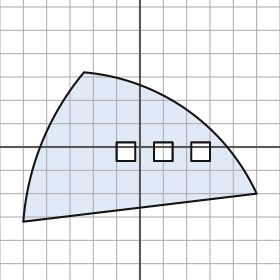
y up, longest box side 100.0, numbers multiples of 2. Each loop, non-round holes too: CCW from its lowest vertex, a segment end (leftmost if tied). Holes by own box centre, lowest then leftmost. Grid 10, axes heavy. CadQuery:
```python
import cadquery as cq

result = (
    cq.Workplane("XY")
    .moveTo(-50.0, -32.0)
    .lineTo(50.0, -20.0)
    .threePointArc((20.0, 16.0), (-24.0, 32.0))
    .threePointArc((-42.0, 2.0), (-50.0, -32.0))
    .close()
    .moveTo(-10.0, -6.0)
    .lineTo(-2.0, -6.0)
    .lineTo(-2.0, 2.0)
    .lineTo(-10.0, 2.0)
    .close()
    .moveTo(6.0, -6.0)
    .lineTo(14.0, -6.0)
    .lineTo(14.0, 2.0)
    .lineTo(6.0, 2.0)
    .close()
    .moveTo(22.0, -6.0)
    .lineTo(30.0, -6.0)
    .lineTo(30.0, 2.0)
    .lineTo(22.0, 2.0)
    .close()
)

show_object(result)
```